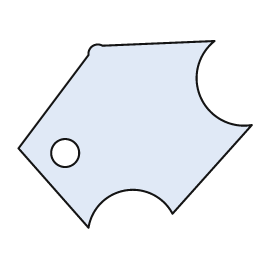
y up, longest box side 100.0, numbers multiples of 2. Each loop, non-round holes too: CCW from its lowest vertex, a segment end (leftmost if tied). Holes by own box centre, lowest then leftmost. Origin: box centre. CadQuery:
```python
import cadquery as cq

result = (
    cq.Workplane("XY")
    .moveTo(-20.0, -40.0)
    .threePointArc((-4.0, -24.0), (16.0, -34.0))
    .lineTo(50.0, 4.0)
    .threePointArc((28.0, 16.0), (34.0, 40.0))
    .lineTo(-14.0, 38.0)
    .threePointArc((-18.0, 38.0), (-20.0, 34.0))
    .lineTo(-50.0, -6.0)
    .close()
    .moveTo(-30.0, -8.0)
    .circle(6.0)
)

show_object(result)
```